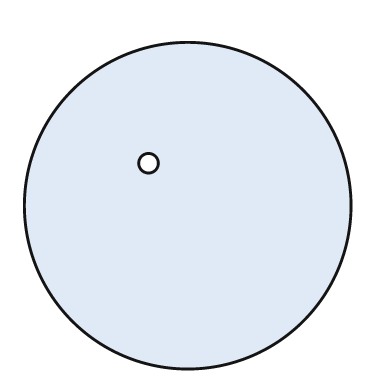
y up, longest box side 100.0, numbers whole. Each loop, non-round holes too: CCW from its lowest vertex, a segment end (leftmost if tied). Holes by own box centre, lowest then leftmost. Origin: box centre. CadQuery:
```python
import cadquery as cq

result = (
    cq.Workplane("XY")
    .moveTo(0.0, 0.0)
    .circle(50.0)
    .moveTo(-12.0, 13.0)
    .circle(3.0)
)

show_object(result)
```